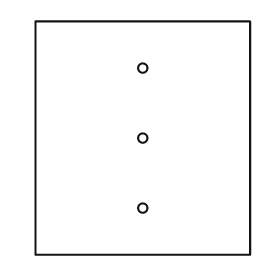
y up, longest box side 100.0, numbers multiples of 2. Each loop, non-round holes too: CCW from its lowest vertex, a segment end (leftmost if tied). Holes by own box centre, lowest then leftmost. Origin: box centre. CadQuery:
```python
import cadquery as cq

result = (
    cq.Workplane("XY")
    .moveTo(-46.0, -50.0)
    .lineTo(46.0, -50.0)
    .lineTo(46.0, 50.0)
    .lineTo(-46.0, 50.0)
    .close()
    .moveTo(0.0, -30.0)
    .circle(2.0)
    .moveTo(0.0, 0.0)
    .circle(2.0)
    .moveTo(0.0, 30.0)
    .circle(2.0)
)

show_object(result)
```